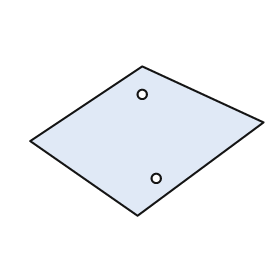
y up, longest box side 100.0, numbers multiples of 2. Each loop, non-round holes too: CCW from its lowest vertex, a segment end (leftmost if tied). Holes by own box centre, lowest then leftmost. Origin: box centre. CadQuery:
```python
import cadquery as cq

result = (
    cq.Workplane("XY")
    .moveTo(-4.0, -32.0)
    .lineTo(50.0, 8.0)
    .lineTo(-2.0, 32.0)
    .lineTo(-50.0, 0.0)
    .close()
    .moveTo(4.0, -16.0)
    .circle(2.0)
    .moveTo(-2.0, 20.0)
    .circle(2.0)
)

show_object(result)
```